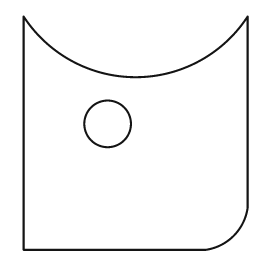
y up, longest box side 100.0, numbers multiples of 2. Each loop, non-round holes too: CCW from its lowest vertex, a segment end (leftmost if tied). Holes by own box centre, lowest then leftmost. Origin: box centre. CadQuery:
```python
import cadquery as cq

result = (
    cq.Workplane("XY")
    .moveTo(-48.0, -50.0)
    .lineTo(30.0, -50.0)
    .threePointArc((42.0, -44.0), (48.0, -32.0))
    .lineTo(48.0, 50.0)
    .threePointArc((0.0, 24.0), (-48.0, 50.0))
    .close()
    .moveTo(-12.0, 4.0)
    .circle(10.0)
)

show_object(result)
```